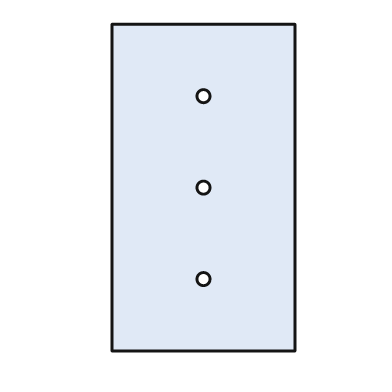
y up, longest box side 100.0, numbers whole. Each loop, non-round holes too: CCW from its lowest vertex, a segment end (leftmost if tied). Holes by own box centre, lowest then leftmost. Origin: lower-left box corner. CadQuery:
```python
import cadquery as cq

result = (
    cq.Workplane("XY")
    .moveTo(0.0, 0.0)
    .lineTo(56.0, 0.0)
    .lineTo(56.0, 100.0)
    .lineTo(0.0, 100.0)
    .close()
    .moveTo(28.0, 22.0)
    .circle(2.0)
    .moveTo(28.0, 50.0)
    .circle(2.0)
    .moveTo(28.0, 78.0)
    .circle(2.0)
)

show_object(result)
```